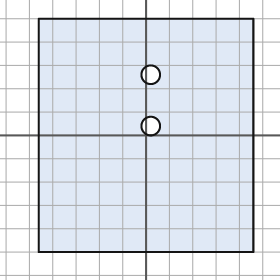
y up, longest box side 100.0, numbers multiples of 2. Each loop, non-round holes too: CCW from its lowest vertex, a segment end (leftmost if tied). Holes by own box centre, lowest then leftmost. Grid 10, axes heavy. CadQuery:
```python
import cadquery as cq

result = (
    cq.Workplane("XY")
    .moveTo(-46.0, -50.0)
    .lineTo(46.0, -50.0)
    .lineTo(46.0, 50.0)
    .lineTo(-46.0, 50.0)
    .close()
    .moveTo(2.0, 4.0)
    .circle(4.0)
    .moveTo(2.0, 26.0)
    .circle(4.0)
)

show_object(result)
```